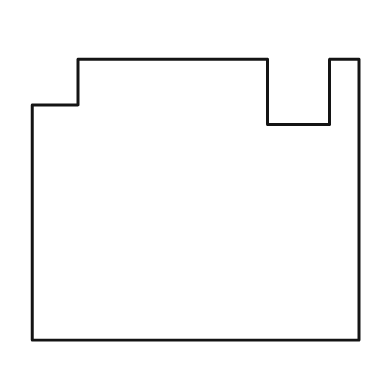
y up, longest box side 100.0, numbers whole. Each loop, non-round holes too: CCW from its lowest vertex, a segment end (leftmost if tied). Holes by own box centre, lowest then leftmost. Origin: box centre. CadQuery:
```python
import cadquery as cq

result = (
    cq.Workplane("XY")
    .moveTo(-50.0, -43.0)
    .lineTo(50.0, -43.0)
    .lineTo(50.0, 43.0)
    .lineTo(41.0, 43.0)
    .lineTo(41.0, 23.0)
    .lineTo(22.0, 23.0)
    .lineTo(22.0, 43.0)
    .lineTo(-36.0, 43.0)
    .lineTo(-36.0, 29.0)
    .lineTo(-50.0, 29.0)
    .close()
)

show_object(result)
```